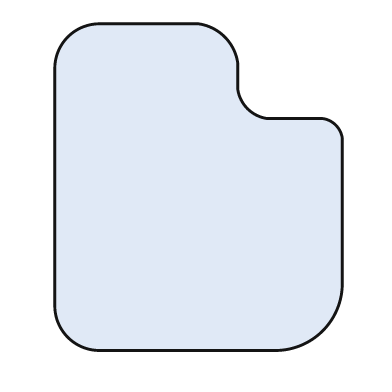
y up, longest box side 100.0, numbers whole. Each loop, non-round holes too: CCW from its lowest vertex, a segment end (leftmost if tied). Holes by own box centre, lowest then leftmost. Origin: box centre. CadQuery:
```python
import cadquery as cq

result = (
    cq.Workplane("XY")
    .moveTo(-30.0, -50.0)
    .lineTo(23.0, -50.0)
    .threePointArc((38.0, -44.0), (44.0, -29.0))
    .lineTo(44.0, 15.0)
    .threePointArc((42.0, 19.0), (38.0, 21.0))
    .lineTo(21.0, 21.0)
    .threePointArc((15.0, 24.0), (12.0, 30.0))
    .lineTo(12.0, 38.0)
    .threePointArc((8.0, 46.0), (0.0, 50.0))
    .lineTo(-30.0, 50.0)
    .threePointArc((-40.0, 46.0), (-44.0, 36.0))
    .lineTo(-44.0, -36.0)
    .threePointArc((-40.0, -46.0), (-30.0, -50.0))
    .close()
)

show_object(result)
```